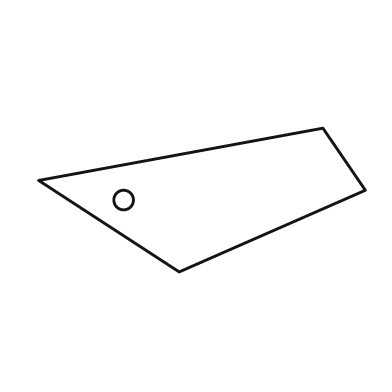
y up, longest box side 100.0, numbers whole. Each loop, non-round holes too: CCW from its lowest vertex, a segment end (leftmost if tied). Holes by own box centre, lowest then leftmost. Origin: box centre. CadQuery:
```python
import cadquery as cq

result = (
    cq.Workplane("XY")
    .moveTo(-7.0, -22.0)
    .lineTo(50.0, 3.0)
    .lineTo(37.0, 22.0)
    .lineTo(-50.0, 6.0)
    .close()
    .moveTo(-24.0, 0.0)
    .circle(3.0)
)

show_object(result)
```